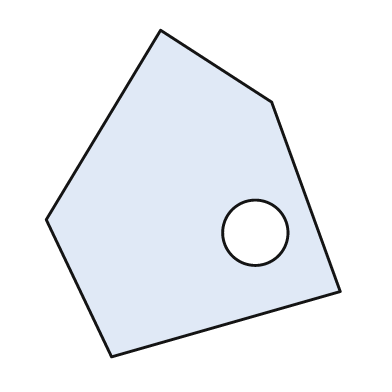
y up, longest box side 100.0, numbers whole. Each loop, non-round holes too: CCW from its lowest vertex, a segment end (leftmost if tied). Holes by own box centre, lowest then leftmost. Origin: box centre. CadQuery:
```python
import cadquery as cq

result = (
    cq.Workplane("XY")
    .moveTo(-25.0, -50.0)
    .lineTo(45.0, -30.0)
    .lineTo(24.0, 28.0)
    .lineTo(-10.0, 50.0)
    .lineTo(-45.0, -8.0)
    .close()
    .moveTo(19.0, -12.0)
    .circle(10.0)
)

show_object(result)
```